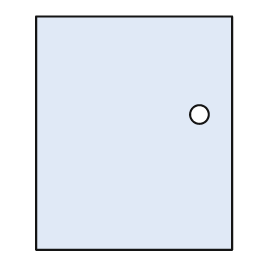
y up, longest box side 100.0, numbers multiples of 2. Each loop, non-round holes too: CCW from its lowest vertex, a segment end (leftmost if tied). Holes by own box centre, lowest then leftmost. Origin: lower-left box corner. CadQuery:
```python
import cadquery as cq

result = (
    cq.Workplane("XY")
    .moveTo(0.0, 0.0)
    .lineTo(84.0, 0.0)
    .lineTo(84.0, 100.0)
    .lineTo(0.0, 100.0)
    .close()
    .moveTo(70.0, 58.0)
    .circle(4.0)
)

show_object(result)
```